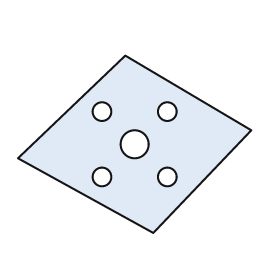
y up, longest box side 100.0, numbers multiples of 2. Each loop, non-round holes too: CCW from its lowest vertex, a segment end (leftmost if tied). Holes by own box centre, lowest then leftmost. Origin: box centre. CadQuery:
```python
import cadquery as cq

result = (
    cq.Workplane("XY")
    .moveTo(8.0, -38.0)
    .lineTo(50.0, 6.0)
    .lineTo(-4.0, 38.0)
    .lineTo(-50.0, -6.0)
    .close()
    .moveTo(-14.0, -14.0)
    .circle(4.0)
    .moveTo(14.0, -14.0)
    .circle(4.0)
    .moveTo(0.0, 0.0)
    .circle(6.0)
    .moveTo(-14.0, 14.0)
    .circle(4.0)
    .moveTo(14.0, 14.0)
    .circle(4.0)
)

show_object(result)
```